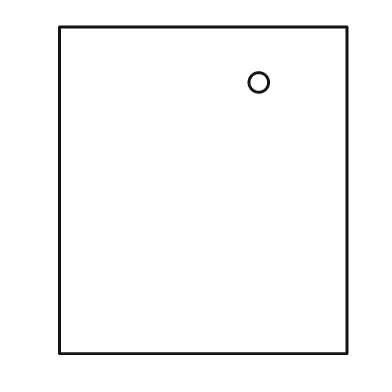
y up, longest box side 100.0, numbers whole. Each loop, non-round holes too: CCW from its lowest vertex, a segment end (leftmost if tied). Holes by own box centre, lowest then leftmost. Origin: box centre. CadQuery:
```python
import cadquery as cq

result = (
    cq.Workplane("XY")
    .moveTo(-44.0, -50.0)
    .lineTo(44.0, -50.0)
    .lineTo(44.0, 50.0)
    .lineTo(-44.0, 50.0)
    .close()
    .moveTo(17.0, 33.0)
    .circle(3.0)
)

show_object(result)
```